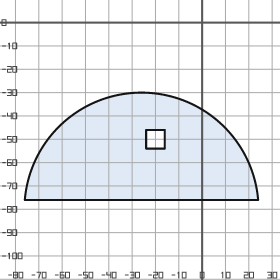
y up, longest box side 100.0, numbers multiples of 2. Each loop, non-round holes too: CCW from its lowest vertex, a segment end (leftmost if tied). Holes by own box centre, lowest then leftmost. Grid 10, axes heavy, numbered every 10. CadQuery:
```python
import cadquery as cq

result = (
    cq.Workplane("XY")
    .moveTo(-76.0, -76.0)
    .lineTo(24.0, -76.0)
    .threePointArc((-26.0, -30.0), (-76.0, -76.0))
    .close()
    .moveTo(-24.0, -54.0)
    .lineTo(-16.0, -54.0)
    .lineTo(-16.0, -46.0)
    .lineTo(-24.0, -46.0)
    .close()
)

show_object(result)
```